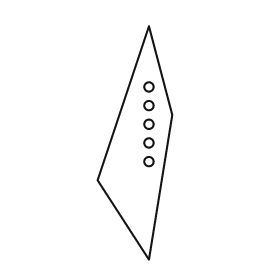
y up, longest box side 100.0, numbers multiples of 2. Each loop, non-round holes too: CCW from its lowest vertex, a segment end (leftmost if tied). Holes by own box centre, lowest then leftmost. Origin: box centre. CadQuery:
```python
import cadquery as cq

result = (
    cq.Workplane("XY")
    .moveTo(6.0, -50.0)
    .lineTo(16.0, 12.0)
    .lineTo(6.0, 50.0)
    .lineTo(-16.0, -16.0)
    .close()
    .moveTo(6.0, -8.0)
    .circle(2.0)
    .moveTo(6.0, 0.0)
    .circle(2.0)
    .moveTo(6.0, 8.0)
    .circle(2.0)
    .moveTo(6.0, 16.0)
    .circle(2.0)
    .moveTo(6.0, 24.0)
    .circle(2.0)
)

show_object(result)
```